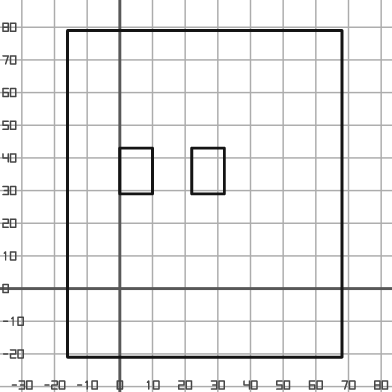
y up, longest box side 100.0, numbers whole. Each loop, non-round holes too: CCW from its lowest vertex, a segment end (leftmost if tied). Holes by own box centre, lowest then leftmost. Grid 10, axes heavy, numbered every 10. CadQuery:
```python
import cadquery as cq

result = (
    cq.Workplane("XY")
    .moveTo(-16.0, -21.0)
    .lineTo(68.0, -21.0)
    .lineTo(68.0, 79.0)
    .lineTo(-16.0, 79.0)
    .close()
    .moveTo(0.0, 29.0)
    .lineTo(10.0, 29.0)
    .lineTo(10.0, 43.0)
    .lineTo(0.0, 43.0)
    .close()
    .moveTo(22.0, 29.0)
    .lineTo(32.0, 29.0)
    .lineTo(32.0, 43.0)
    .lineTo(22.0, 43.0)
    .close()
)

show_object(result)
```